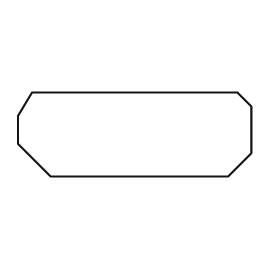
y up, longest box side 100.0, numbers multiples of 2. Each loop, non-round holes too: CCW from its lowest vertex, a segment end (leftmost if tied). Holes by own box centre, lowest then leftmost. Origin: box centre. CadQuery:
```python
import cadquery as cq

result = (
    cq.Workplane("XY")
    .moveTo(-36.0, -18.0)
    .lineTo(40.0, -18.0)
    .lineTo(50.0, -8.0)
    .lineTo(50.0, 12.0)
    .lineTo(44.0, 18.0)
    .lineTo(-44.0, 18.0)
    .lineTo(-50.0, 8.0)
    .lineTo(-50.0, -4.0)
    .close()
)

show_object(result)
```